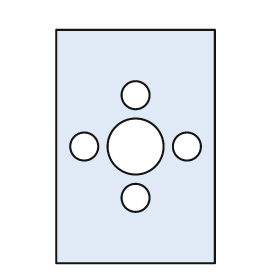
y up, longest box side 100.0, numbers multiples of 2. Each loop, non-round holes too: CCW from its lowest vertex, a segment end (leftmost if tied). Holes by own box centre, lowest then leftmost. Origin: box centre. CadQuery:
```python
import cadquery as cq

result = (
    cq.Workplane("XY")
    .moveTo(-34.0, -50.0)
    .lineTo(34.0, -50.0)
    .lineTo(34.0, 50.0)
    .lineTo(-34.0, 50.0)
    .close()
    .moveTo(0.0, -22.0)
    .circle(6.0)
    .moveTo(-22.0, 0.0)
    .circle(6.0)
    .moveTo(0.0, 0.0)
    .circle(12.0)
    .moveTo(22.0, 0.0)
    .circle(6.0)
    .moveTo(0.0, 22.0)
    .circle(6.0)
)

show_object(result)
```